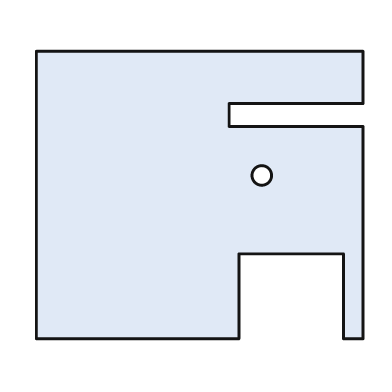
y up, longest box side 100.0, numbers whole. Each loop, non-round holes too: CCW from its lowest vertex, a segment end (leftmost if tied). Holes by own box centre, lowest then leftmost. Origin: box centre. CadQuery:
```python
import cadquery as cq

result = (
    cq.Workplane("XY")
    .moveTo(-50.0, -44.0)
    .lineTo(12.0, -44.0)
    .lineTo(12.0, -18.0)
    .lineTo(44.0, -18.0)
    .lineTo(44.0, -44.0)
    .lineTo(50.0, -44.0)
    .lineTo(50.0, 21.0)
    .lineTo(9.0, 21.0)
    .lineTo(9.0, 28.0)
    .lineTo(50.0, 28.0)
    .lineTo(50.0, 44.0)
    .lineTo(-50.0, 44.0)
    .close()
    .moveTo(19.0, 6.0)
    .circle(3.0)
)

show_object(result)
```